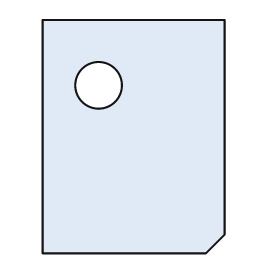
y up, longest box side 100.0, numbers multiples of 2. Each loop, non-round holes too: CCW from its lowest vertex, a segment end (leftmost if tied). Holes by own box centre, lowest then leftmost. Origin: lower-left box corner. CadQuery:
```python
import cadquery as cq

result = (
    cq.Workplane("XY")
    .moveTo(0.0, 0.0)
    .lineTo(70.0, 0.0)
    .lineTo(78.0, 8.0)
    .lineTo(78.0, 100.0)
    .lineTo(0.0, 100.0)
    .close()
    .moveTo(24.0, 72.0)
    .circle(10.0)
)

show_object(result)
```